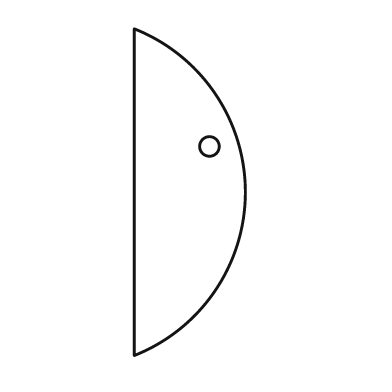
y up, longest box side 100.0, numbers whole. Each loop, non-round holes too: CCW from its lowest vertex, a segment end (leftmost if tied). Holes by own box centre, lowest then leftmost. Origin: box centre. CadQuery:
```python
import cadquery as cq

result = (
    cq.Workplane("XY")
    .moveTo(-17.0, -50.0)
    .threePointArc((17.0, 0.0), (-17.0, 50.0))
    .close()
    .moveTo(6.0, 14.0)
    .circle(3.0)
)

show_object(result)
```